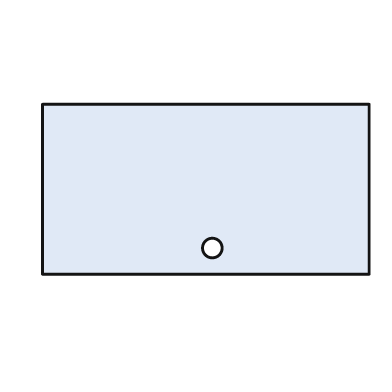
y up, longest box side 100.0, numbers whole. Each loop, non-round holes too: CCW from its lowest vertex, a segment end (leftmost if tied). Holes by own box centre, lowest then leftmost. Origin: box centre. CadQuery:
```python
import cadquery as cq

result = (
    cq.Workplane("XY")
    .moveTo(-50.0, -26.0)
    .lineTo(50.0, -26.0)
    .lineTo(50.0, 26.0)
    .lineTo(-50.0, 26.0)
    .close()
    .moveTo(2.0, -18.0)
    .circle(3.0)
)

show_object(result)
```